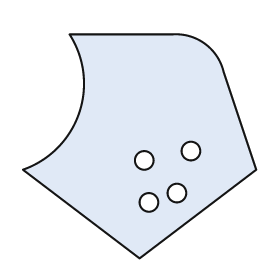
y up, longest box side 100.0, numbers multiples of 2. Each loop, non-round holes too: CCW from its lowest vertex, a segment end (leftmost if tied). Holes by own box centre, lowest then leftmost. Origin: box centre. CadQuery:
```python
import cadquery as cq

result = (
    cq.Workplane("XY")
    .moveTo(0.0, -48.0)
    .lineTo(50.0, -10.0)
    .lineTo(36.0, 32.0)
    .threePointArc((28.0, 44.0), (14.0, 48.0))
    .lineTo(-30.0, 48.0)
    .threePointArc((-26.0, 14.0), (-50.0, -10.0))
    .close()
    .moveTo(4.0, -24.0)
    .circle(4.0)
    .moveTo(16.0, -20.0)
    .circle(4.0)
    .moveTo(2.0, -6.0)
    .circle(4.0)
    .moveTo(22.0, -2.0)
    .circle(4.0)
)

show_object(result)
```